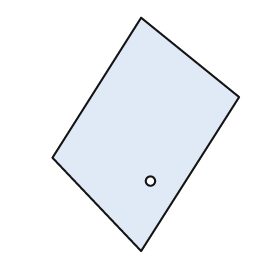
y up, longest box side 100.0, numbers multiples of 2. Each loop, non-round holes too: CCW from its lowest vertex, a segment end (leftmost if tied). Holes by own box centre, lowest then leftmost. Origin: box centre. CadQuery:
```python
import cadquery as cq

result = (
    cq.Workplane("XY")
    .moveTo(-2.0, -50.0)
    .lineTo(40.0, 16.0)
    .lineTo(-2.0, 50.0)
    .lineTo(-40.0, -10.0)
    .close()
    .moveTo(2.0, -20.0)
    .circle(2.0)
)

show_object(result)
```